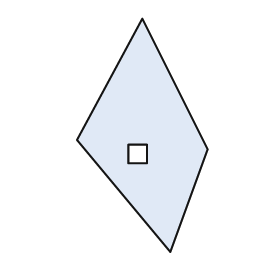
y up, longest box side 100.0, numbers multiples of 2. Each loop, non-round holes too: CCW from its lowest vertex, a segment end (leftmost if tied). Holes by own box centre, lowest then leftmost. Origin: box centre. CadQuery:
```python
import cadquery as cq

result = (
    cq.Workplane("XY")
    .moveTo(12.0, -50.0)
    .lineTo(28.0, -6.0)
    .lineTo(0.0, 50.0)
    .lineTo(-28.0, -2.0)
    .close()
    .moveTo(-6.0, -12.0)
    .lineTo(2.0, -12.0)
    .lineTo(2.0, -4.0)
    .lineTo(-6.0, -4.0)
    .close()
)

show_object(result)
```